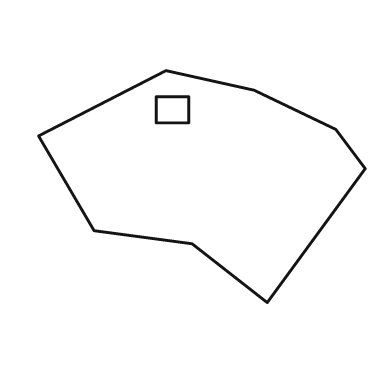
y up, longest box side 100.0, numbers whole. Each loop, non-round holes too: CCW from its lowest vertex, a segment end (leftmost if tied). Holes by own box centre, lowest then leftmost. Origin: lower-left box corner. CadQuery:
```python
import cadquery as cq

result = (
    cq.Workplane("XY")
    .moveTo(70.0, 0.0)
    .lineTo(100.0, 41.0)
    .lineTo(91.0, 53.0)
    .lineTo(66.0, 65.0)
    .lineTo(39.0, 71.0)
    .lineTo(0.0, 51.0)
    .lineTo(17.0, 22.0)
    .lineTo(47.0, 18.0)
    .close()
    .moveTo(36.0, 55.0)
    .lineTo(46.0, 55.0)
    .lineTo(46.0, 63.0)
    .lineTo(36.0, 63.0)
    .close()
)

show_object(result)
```